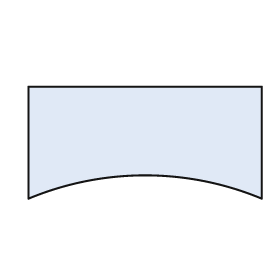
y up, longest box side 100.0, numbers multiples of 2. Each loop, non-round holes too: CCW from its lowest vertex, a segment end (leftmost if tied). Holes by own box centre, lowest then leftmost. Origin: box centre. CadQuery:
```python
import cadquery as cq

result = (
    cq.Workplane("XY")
    .moveTo(-50.0, -24.0)
    .threePointArc((0.0, -14.0), (50.0, -24.0))
    .lineTo(50.0, 24.0)
    .lineTo(-50.0, 24.0)
    .close()
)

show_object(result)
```